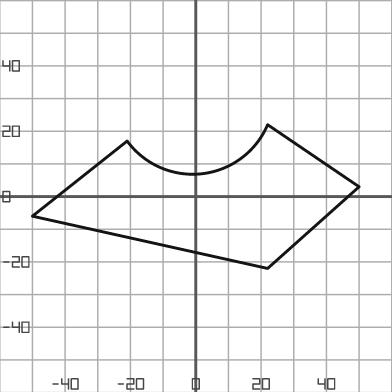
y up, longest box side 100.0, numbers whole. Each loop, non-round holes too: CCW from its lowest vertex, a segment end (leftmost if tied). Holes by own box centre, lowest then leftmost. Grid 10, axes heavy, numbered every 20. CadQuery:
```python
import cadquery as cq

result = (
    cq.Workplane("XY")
    .moveTo(22.0, -22.0)
    .lineTo(50.0, 3.0)
    .lineTo(22.0, 22.0)
    .threePointArc((2.0, 7.0), (-21.0, 17.0))
    .lineTo(-50.0, -6.0)
    .close()
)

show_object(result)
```